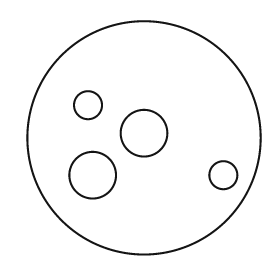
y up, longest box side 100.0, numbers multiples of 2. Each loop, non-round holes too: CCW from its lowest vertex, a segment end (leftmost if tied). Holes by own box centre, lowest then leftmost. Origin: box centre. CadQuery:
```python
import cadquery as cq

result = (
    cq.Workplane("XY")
    .moveTo(0.0, 0.0)
    .circle(50.0)
    .moveTo(-22.0, -16.0)
    .circle(10.0)
    .moveTo(34.0, -16.0)
    .circle(6.0)
    .moveTo(0.0, 2.0)
    .circle(10.0)
    .moveTo(-24.0, 14.0)
    .circle(6.0)
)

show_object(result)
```